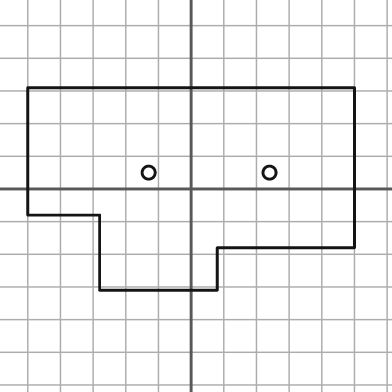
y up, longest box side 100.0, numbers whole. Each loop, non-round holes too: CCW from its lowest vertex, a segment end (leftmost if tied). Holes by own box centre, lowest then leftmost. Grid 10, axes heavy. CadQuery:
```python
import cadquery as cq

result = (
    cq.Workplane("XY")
    .moveTo(-28.0, -31.0)
    .lineTo(8.0, -31.0)
    .lineTo(8.0, -18.0)
    .lineTo(50.0, -18.0)
    .lineTo(50.0, 31.0)
    .lineTo(-50.0, 31.0)
    .lineTo(-50.0, -8.0)
    .lineTo(-28.0, -8.0)
    .close()
    .moveTo(-13.0, 5.0)
    .circle(2.0)
    .moveTo(24.0, 5.0)
    .circle(2.0)
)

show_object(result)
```